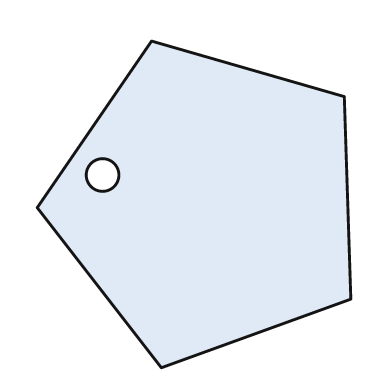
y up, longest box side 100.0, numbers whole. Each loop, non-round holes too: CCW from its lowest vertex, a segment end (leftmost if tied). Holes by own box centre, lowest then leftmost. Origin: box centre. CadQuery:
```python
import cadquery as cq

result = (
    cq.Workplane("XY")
    .moveTo(-10.0, -50.0)
    .lineTo(48.0, -29.0)
    .lineTo(46.0, 33.0)
    .lineTo(-13.0, 50.0)
    .lineTo(-48.0, -1.0)
    .close()
    .moveTo(-28.0, 9.0)
    .circle(5.0)
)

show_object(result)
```